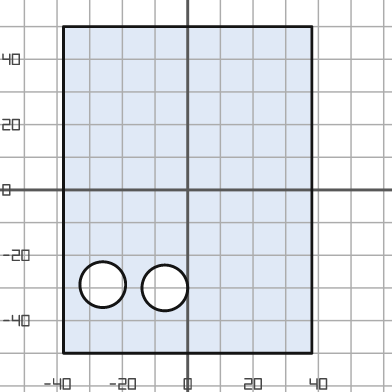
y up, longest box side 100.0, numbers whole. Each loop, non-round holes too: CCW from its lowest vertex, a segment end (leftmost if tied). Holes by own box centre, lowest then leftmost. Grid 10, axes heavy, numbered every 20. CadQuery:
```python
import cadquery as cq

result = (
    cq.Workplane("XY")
    .moveTo(-38.0, -50.0)
    .lineTo(38.0, -50.0)
    .lineTo(38.0, 50.0)
    .lineTo(-38.0, 50.0)
    .close()
    .moveTo(-7.0, -30.0)
    .circle(7.0)
    .moveTo(-26.0, -29.0)
    .circle(7.0)
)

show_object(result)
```